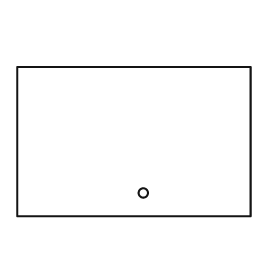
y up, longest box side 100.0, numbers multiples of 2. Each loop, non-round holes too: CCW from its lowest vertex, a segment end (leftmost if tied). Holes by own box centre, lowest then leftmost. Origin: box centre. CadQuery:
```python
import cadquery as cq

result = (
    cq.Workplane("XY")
    .moveTo(-50.0, -32.0)
    .lineTo(50.0, -32.0)
    .lineTo(50.0, 32.0)
    .lineTo(-50.0, 32.0)
    .close()
    .moveTo(4.0, -22.0)
    .circle(2.0)
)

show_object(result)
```